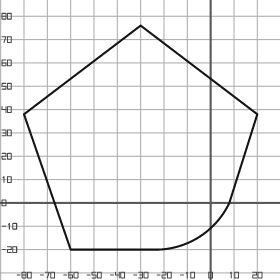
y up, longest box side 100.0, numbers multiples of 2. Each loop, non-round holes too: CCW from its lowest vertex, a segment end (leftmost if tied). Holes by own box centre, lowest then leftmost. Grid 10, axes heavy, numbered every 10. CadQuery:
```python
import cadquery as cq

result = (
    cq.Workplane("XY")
    .moveTo(-60.0, -20.0)
    .lineTo(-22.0, -20.0)
    .threePointArc((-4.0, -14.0), (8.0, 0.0))
    .lineTo(20.0, 38.0)
    .lineTo(-30.0, 76.0)
    .lineTo(-80.0, 38.0)
    .close()
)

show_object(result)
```